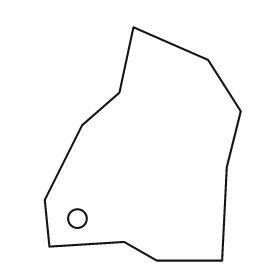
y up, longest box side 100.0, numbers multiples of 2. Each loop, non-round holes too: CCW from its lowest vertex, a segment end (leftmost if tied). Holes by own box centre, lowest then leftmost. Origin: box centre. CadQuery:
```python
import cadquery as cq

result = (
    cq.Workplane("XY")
    .moveTo(6.0, -50.0)
    .lineTo(34.0, -50.0)
    .lineTo(36.0, -10.0)
    .lineTo(42.0, 14.0)
    .lineTo(28.0, 36.0)
    .lineTo(-4.0, 50.0)
    .lineTo(-10.0, 22.0)
    .lineTo(-26.0, 8.0)
    .lineTo(-42.0, -24.0)
    .lineTo(-40.0, -44.0)
    .lineTo(-8.0, -42.0)
    .close()
    .moveTo(-28.0, -32.0)
    .circle(4.0)
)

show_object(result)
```